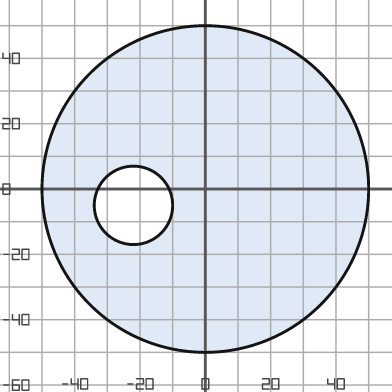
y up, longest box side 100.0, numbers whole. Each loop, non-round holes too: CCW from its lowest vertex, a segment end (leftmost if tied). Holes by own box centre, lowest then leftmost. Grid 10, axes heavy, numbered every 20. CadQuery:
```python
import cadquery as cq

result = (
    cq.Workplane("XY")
    .moveTo(0.0, 0.0)
    .circle(50.0)
    .moveTo(-22.0, -5.0)
    .circle(12.0)
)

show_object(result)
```